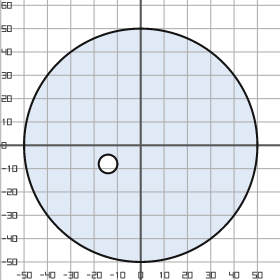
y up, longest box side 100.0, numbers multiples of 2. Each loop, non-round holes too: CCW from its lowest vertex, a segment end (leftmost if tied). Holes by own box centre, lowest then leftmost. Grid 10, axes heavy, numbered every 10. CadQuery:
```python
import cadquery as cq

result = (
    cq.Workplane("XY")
    .moveTo(0.0, 0.0)
    .circle(50.0)
    .moveTo(-14.0, -8.0)
    .circle(4.0)
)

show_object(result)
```